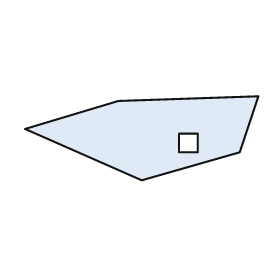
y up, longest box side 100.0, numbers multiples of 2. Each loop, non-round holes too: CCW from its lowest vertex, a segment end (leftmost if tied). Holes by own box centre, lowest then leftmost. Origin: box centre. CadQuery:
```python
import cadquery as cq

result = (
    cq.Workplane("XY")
    .moveTo(0.0, -18.0)
    .lineTo(42.0, -6.0)
    .lineTo(50.0, 18.0)
    .lineTo(-10.0, 16.0)
    .lineTo(-50.0, 4.0)
    .close()
    .moveTo(16.0, -6.0)
    .lineTo(24.0, -6.0)
    .lineTo(24.0, 2.0)
    .lineTo(16.0, 2.0)
    .close()
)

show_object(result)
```